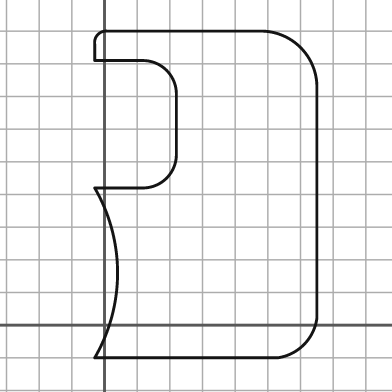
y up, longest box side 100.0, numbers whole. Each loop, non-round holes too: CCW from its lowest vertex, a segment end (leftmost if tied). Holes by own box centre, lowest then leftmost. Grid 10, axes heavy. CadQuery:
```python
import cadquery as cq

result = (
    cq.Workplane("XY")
    .moveTo(-3.0, -10.0)
    .lineTo(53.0, -10.0)
    .threePointArc((61.0, -6.0), (65.0, 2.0))
    .lineTo(65.0, 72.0)
    .threePointArc((60.0, 85.0), (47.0, 90.0))
    .lineTo(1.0, 90.0)
    .threePointArc((-2.0, 89.0), (-3.0, 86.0))
    .lineTo(-3.0, 81.0)
    .lineTo(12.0, 81.0)
    .threePointArc((19.0, 78.0), (22.0, 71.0))
    .lineTo(22.0, 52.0)
    .threePointArc((19.0, 45.0), (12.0, 42.0))
    .lineTo(-3.0, 42.0)
    .threePointArc((4.0, 16.0), (-3.0, -10.0))
    .close()
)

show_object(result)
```